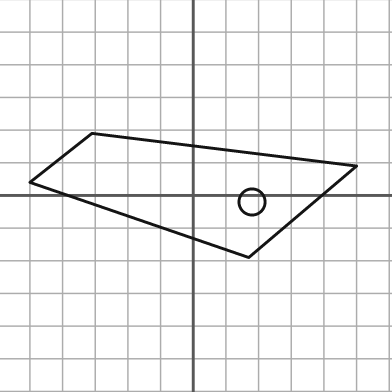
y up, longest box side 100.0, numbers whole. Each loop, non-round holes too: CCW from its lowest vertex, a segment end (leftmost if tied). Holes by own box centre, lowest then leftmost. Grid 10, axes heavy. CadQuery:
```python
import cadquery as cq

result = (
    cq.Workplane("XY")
    .moveTo(17.0, -19.0)
    .lineTo(50.0, 9.0)
    .lineTo(-31.0, 19.0)
    .lineTo(-50.0, 4.0)
    .close()
    .moveTo(18.0, -2.0)
    .circle(4.0)
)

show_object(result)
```